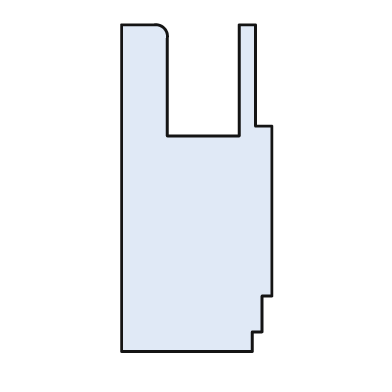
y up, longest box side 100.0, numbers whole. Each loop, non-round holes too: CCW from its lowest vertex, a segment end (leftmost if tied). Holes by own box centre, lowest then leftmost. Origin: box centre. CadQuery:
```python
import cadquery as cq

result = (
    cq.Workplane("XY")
    .moveTo(-23.0, -50.0)
    .lineTo(17.0, -50.0)
    .lineTo(17.0, -44.0)
    .lineTo(20.0, -44.0)
    .lineTo(20.0, -33.0)
    .lineTo(23.0, -33.0)
    .lineTo(23.0, 19.0)
    .lineTo(18.0, 19.0)
    .lineTo(18.0, 50.0)
    .lineTo(13.0, 50.0)
    .lineTo(13.0, 16.0)
    .lineTo(-9.0, 16.0)
    .lineTo(-9.0, 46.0)
    .threePointArc((-10.0, 49.0), (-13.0, 50.0))
    .lineTo(-23.0, 50.0)
    .close()
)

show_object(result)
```